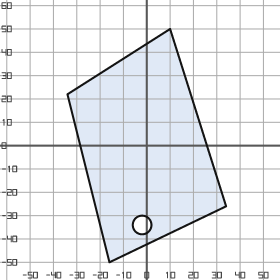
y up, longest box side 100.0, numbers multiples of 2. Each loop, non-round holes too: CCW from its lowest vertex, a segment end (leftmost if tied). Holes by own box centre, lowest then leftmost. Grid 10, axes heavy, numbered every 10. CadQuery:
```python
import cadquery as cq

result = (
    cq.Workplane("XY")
    .moveTo(-16.0, -50.0)
    .lineTo(34.0, -26.0)
    .lineTo(10.0, 50.0)
    .lineTo(-34.0, 22.0)
    .close()
    .moveTo(-2.0, -34.0)
    .circle(4.0)
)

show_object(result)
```